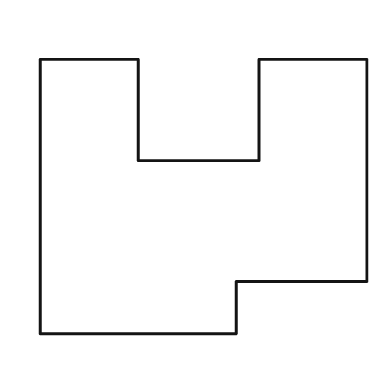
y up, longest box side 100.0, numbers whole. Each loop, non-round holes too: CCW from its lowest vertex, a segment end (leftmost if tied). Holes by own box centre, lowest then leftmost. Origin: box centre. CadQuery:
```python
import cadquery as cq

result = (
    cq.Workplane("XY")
    .moveTo(-50.0, -42.0)
    .lineTo(10.0, -42.0)
    .lineTo(10.0, -26.0)
    .lineTo(50.0, -26.0)
    .lineTo(50.0, 42.0)
    .lineTo(17.0, 42.0)
    .lineTo(17.0, 11.0)
    .lineTo(-20.0, 11.0)
    .lineTo(-20.0, 42.0)
    .lineTo(-50.0, 42.0)
    .close()
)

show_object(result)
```